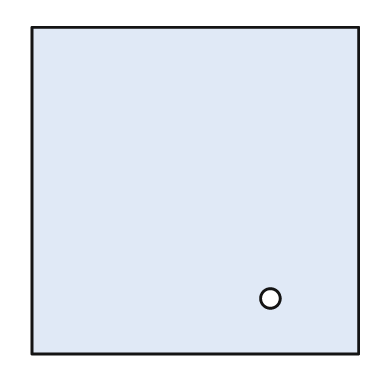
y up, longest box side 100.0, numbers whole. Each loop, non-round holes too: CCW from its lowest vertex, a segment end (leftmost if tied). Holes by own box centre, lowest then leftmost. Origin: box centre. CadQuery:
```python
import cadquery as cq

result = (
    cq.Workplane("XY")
    .moveTo(-50.0, -50.0)
    .lineTo(50.0, -50.0)
    .lineTo(50.0, 50.0)
    .lineTo(-50.0, 50.0)
    .close()
    .moveTo(23.0, -33.0)
    .circle(3.0)
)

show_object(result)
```